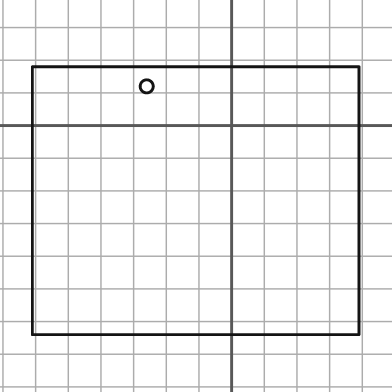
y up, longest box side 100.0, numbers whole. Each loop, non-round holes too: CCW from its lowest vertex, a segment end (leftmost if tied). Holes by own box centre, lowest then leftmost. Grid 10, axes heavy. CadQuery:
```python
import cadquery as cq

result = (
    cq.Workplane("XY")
    .moveTo(-61.0, -64.0)
    .lineTo(39.0, -64.0)
    .lineTo(39.0, 18.0)
    .lineTo(-61.0, 18.0)
    .close()
    .moveTo(-26.0, 12.0)
    .circle(2.0)
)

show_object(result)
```